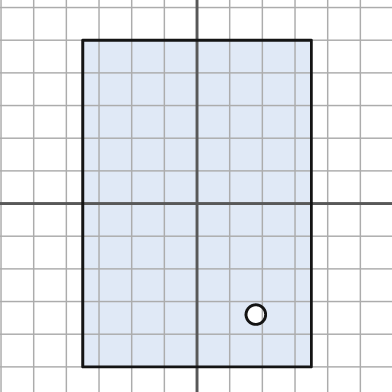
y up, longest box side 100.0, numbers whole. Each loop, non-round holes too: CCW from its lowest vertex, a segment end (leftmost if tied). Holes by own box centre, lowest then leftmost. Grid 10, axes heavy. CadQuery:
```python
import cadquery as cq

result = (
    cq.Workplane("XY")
    .moveTo(-35.0, -50.0)
    .lineTo(35.0, -50.0)
    .lineTo(35.0, 50.0)
    .lineTo(-35.0, 50.0)
    .close()
    .moveTo(18.0, -34.0)
    .circle(3.0)
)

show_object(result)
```